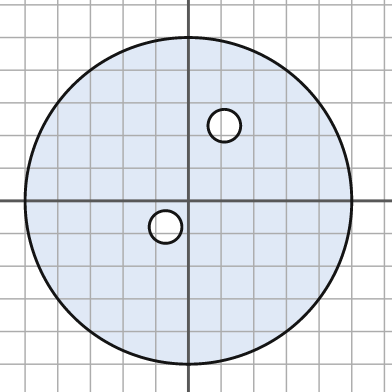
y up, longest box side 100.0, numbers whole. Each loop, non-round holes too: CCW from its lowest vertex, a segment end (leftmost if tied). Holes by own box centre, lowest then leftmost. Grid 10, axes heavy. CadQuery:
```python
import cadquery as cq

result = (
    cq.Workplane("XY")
    .moveTo(0.0, 0.0)
    .circle(50.0)
    .moveTo(-7.0, -8.0)
    .circle(5.0)
    .moveTo(11.0, 23.0)
    .circle(5.0)
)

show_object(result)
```